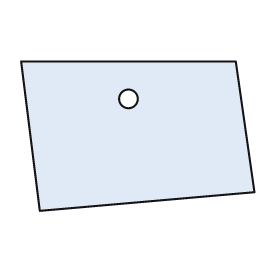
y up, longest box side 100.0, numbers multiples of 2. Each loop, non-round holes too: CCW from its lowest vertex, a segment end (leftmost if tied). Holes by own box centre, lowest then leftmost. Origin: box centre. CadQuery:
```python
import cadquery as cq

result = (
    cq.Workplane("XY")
    .moveTo(-42.0, -32.0)
    .lineTo(50.0, -24.0)
    .lineTo(42.0, 32.0)
    .lineTo(-50.0, 32.0)
    .close()
    .moveTo(-4.0, 16.0)
    .circle(4.0)
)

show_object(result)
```